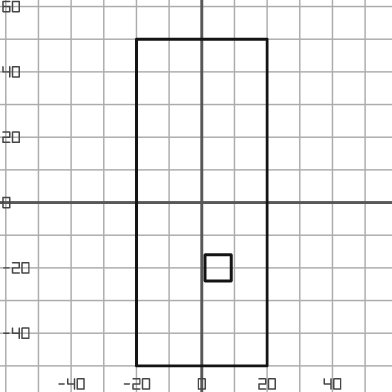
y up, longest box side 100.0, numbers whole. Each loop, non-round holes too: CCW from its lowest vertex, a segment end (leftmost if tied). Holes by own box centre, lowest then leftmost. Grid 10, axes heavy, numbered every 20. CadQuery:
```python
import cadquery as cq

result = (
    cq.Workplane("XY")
    .moveTo(-20.0, -50.0)
    .lineTo(20.0, -50.0)
    .lineTo(20.0, 50.0)
    .lineTo(-20.0, 50.0)
    .close()
    .moveTo(1.0, -24.0)
    .lineTo(9.0, -24.0)
    .lineTo(9.0, -16.0)
    .lineTo(1.0, -16.0)
    .close()
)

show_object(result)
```